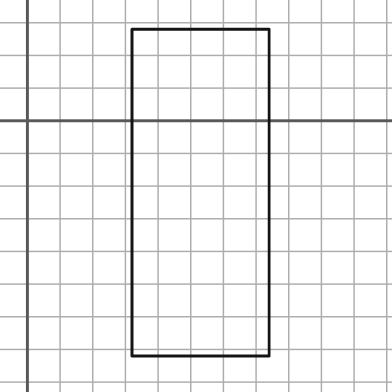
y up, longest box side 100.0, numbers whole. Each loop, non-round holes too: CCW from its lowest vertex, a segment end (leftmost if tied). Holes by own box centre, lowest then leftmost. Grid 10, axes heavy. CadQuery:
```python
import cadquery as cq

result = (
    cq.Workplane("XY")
    .moveTo(32.0, -72.0)
    .lineTo(74.0, -72.0)
    .lineTo(74.0, 28.0)
    .lineTo(32.0, 28.0)
    .close()
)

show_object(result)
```